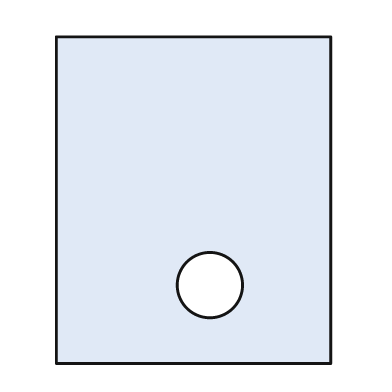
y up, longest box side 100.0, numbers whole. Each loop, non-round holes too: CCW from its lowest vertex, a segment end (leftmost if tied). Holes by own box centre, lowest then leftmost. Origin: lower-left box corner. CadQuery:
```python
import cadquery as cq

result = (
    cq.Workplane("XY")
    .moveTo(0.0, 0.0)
    .lineTo(84.0, 0.0)
    .lineTo(84.0, 100.0)
    .lineTo(0.0, 100.0)
    .close()
    .moveTo(47.0, 24.0)
    .circle(10.0)
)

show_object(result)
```